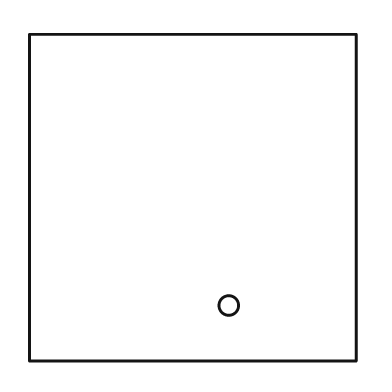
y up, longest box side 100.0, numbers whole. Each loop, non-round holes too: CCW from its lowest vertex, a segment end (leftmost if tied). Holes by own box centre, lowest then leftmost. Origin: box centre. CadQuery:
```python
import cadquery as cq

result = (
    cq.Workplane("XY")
    .moveTo(-50.0, -50.0)
    .lineTo(50.0, -50.0)
    .lineTo(50.0, 50.0)
    .lineTo(-50.0, 50.0)
    .close()
    .moveTo(11.0, -33.0)
    .circle(3.0)
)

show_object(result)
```